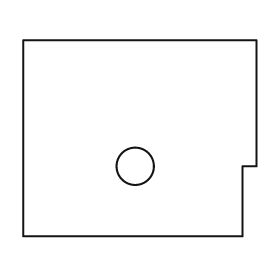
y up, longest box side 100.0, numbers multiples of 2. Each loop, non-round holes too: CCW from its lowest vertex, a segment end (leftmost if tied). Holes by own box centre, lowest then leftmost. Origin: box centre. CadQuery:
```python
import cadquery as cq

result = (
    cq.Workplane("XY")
    .moveTo(-50.0, -42.0)
    .lineTo(44.0, -42.0)
    .lineTo(44.0, -12.0)
    .lineTo(50.0, -12.0)
    .lineTo(50.0, 42.0)
    .lineTo(-50.0, 42.0)
    .close()
    .moveTo(-2.0, -12.0)
    .circle(8.0)
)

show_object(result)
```